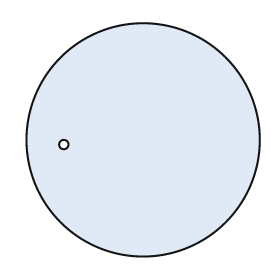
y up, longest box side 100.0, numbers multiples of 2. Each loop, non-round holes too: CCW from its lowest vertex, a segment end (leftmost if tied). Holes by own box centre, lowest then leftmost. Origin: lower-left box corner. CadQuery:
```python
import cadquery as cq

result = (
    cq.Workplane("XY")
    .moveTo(50.0, 50.0)
    .circle(50.0)
    .moveTo(16.0, 48.0)
    .circle(2.0)
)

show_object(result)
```